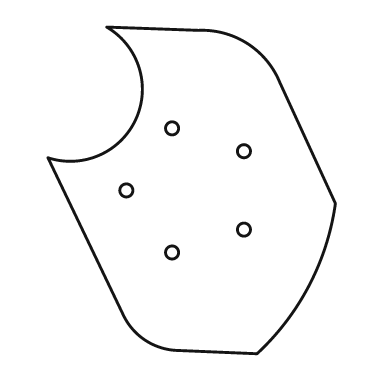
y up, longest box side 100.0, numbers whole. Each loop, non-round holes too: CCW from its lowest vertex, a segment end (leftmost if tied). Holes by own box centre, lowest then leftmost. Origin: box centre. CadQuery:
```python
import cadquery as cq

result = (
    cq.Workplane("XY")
    .moveTo(20.0, -50.0)
    .threePointArc((36.0, -29.0), (44.0, -4.0))
    .lineTo(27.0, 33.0)
    .threePointArc((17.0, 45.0), (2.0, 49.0))
    .lineTo(-26.0, 50.0)
    .threePointArc((-17.0, 22.0), (-44.0, 10.0))
    .lineTo(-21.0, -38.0)
    .threePointArc((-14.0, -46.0), (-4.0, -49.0))
    .close()
    .moveTo(-6.0, -19.0)
    .circle(2.0)
    .moveTo(16.0, -12.0)
    .circle(2.0)
    .moveTo(-20.0, 0.0)
    .circle(2.0)
    .moveTo(16.0, 12.0)
    .circle(2.0)
    .moveTo(-6.0, 19.0)
    .circle(2.0)
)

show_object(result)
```